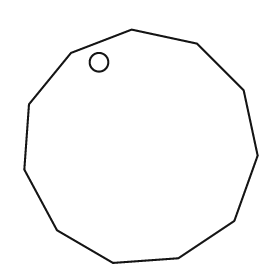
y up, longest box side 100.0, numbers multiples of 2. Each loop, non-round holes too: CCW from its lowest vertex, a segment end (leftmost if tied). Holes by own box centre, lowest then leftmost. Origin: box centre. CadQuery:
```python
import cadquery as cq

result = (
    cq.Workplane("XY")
    .moveTo(-12.0, -50.0)
    .lineTo(16.0, -48.0)
    .lineTo(40.0, -32.0)
    .lineTo(50.0, -4.0)
    .lineTo(44.0, 24.0)
    .lineTo(24.0, 44.0)
    .lineTo(-4.0, 50.0)
    .lineTo(-30.0, 40.0)
    .lineTo(-48.0, 18.0)
    .lineTo(-50.0, -10.0)
    .lineTo(-36.0, -36.0)
    .close()
    .moveTo(-18.0, 36.0)
    .circle(4.0)
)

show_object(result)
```